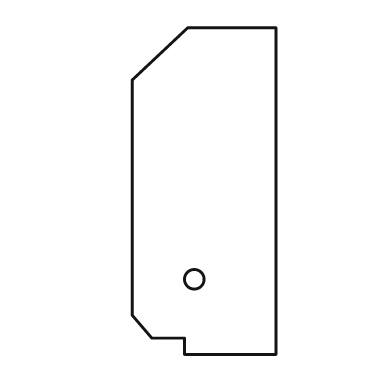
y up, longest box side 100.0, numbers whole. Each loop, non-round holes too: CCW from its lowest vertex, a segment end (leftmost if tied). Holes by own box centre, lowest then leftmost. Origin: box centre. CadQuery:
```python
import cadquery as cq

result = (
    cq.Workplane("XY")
    .moveTo(-6.0, -50.0)
    .lineTo(22.0, -50.0)
    .lineTo(22.0, 50.0)
    .lineTo(-5.0, 50.0)
    .lineTo(-22.0, 34.0)
    .lineTo(-22.0, -38.0)
    .lineTo(-16.0, -45.0)
    .lineTo(-6.0, -45.0)
    .close()
    .moveTo(-3.0, -27.0)
    .circle(3.0)
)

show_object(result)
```